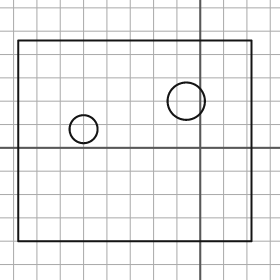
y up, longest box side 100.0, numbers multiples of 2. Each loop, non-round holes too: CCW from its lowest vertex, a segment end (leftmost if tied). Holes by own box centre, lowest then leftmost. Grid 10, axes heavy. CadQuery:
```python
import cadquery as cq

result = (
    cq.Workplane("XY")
    .moveTo(-78.0, -40.0)
    .lineTo(22.0, -40.0)
    .lineTo(22.0, 46.0)
    .lineTo(-78.0, 46.0)
    .close()
    .moveTo(-50.0, 8.0)
    .circle(6.0)
    .moveTo(-6.0, 20.0)
    .circle(8.0)
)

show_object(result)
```